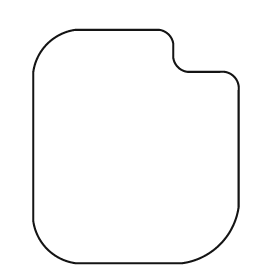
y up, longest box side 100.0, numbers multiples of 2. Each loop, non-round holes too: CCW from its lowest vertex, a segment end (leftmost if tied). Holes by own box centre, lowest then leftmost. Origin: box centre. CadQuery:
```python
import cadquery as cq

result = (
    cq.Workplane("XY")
    .moveTo(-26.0, -50.0)
    .lineTo(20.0, -50.0)
    .threePointArc((36.0, -42.0), (44.0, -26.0))
    .lineTo(44.0, 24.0)
    .threePointArc((42.0, 30.0), (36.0, 32.0))
    .lineTo(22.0, 32.0)
    .threePointArc((18.0, 34.0), (16.0, 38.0))
    .lineTo(16.0, 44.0)
    .threePointArc((14.0, 48.0), (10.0, 50.0))
    .lineTo(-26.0, 50.0)
    .threePointArc((-38.0, 44.0), (-44.0, 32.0))
    .lineTo(-44.0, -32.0)
    .threePointArc((-38.0, -44.0), (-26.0, -50.0))
    .close()
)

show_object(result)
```